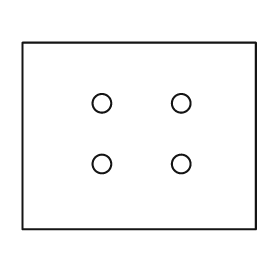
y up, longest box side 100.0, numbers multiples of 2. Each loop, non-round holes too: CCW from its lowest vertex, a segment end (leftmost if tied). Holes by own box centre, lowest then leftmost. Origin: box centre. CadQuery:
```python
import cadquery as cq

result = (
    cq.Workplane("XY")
    .moveTo(-50.0, -40.0)
    .lineTo(50.0, -40.0)
    .lineTo(50.0, 40.0)
    .lineTo(-50.0, 40.0)
    .close()
    .moveTo(-16.0, -12.0)
    .circle(4.0)
    .moveTo(18.0, -12.0)
    .circle(4.0)
    .moveTo(-16.0, 14.0)
    .circle(4.0)
    .moveTo(18.0, 14.0)
    .circle(4.0)
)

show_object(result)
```